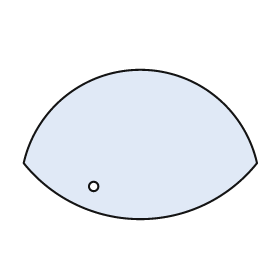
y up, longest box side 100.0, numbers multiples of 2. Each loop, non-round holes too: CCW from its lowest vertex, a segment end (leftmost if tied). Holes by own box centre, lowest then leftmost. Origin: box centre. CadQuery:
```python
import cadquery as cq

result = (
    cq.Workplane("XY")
    .moveTo(-50.0, -8.0)
    .threePointArc((0.0, -32.0), (50.0, -8.0))
    .threePointArc((0.0, 32.0), (-50.0, -8.0))
    .close()
    .moveTo(-20.0, -18.0)
    .circle(2.0)
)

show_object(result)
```